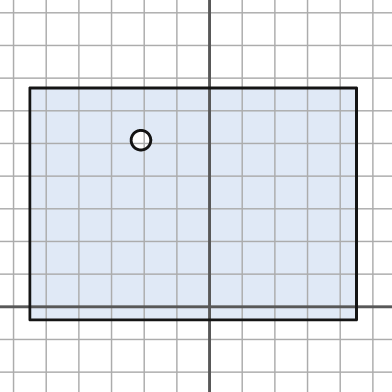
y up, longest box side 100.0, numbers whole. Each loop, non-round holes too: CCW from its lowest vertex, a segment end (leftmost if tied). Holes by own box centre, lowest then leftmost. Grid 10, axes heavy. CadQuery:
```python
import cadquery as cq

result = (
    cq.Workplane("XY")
    .moveTo(-55.0, -4.0)
    .lineTo(45.0, -4.0)
    .lineTo(45.0, 67.0)
    .lineTo(-55.0, 67.0)
    .close()
    .moveTo(-21.0, 51.0)
    .circle(3.0)
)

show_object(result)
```